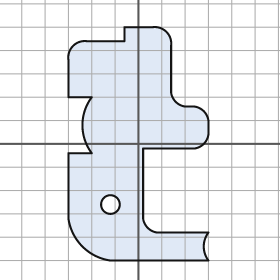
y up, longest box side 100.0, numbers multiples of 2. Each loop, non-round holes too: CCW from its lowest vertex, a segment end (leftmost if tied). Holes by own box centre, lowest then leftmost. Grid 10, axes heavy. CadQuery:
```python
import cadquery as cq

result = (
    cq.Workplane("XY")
    .moveTo(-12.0, -50.0)
    .lineTo(30.0, -50.0)
    .threePointArc((28.0, -44.0), (30.0, -38.0))
    .lineTo(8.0, -38.0)
    .threePointArc((4.0, -36.0), (2.0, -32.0))
    .lineTo(2.0, -2.0)
    .lineTo(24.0, -2.0)
    .threePointArc((28.0, 0.0), (30.0, 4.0))
    .lineTo(30.0, 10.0)
    .threePointArc((28.0, 14.0), (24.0, 16.0))
    .lineTo(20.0, 16.0)
    .threePointArc((16.0, 18.0), (14.0, 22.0))
    .lineTo(14.0, 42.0)
    .threePointArc((12.0, 48.0), (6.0, 50.0))
    .lineTo(-6.0, 50.0)
    .lineTo(-6.0, 44.0)
    .lineTo(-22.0, 44.0)
    .threePointArc((-28.0, 42.0), (-30.0, 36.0))
    .lineTo(-30.0, 20.0)
    .lineTo(-20.0, 20.0)
    .threePointArc((-24.0, 8.0), (-20.0, -4.0))
    .lineTo(-30.0, -4.0)
    .lineTo(-30.0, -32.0)
    .threePointArc((-24.0, -44.0), (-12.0, -50.0))
    .close()
    .moveTo(-12.0, -26.0)
    .circle(4.0)
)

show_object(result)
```